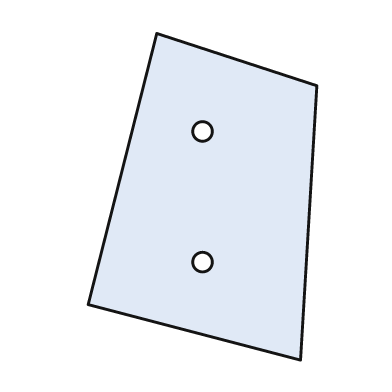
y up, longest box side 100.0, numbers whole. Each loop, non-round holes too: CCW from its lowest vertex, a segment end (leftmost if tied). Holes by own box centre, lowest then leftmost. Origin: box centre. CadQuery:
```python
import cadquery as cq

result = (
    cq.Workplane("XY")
    .moveTo(30.0, -50.0)
    .lineTo(35.0, 34.0)
    .lineTo(-14.0, 50.0)
    .lineTo(-35.0, -33.0)
    .close()
    .moveTo(0.0, -20.0)
    .circle(3.0)
    .moveTo(0.0, 20.0)
    .circle(3.0)
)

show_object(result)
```